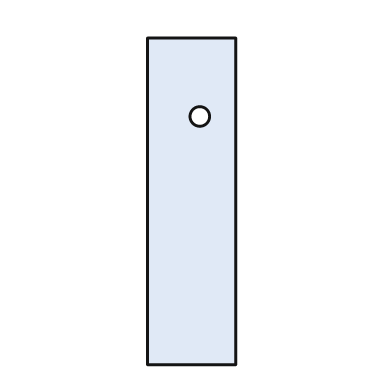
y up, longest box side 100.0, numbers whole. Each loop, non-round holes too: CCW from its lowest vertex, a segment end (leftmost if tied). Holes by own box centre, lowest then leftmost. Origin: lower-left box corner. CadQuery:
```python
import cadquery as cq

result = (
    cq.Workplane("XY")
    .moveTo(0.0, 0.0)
    .lineTo(27.0, 0.0)
    .lineTo(27.0, 100.0)
    .lineTo(0.0, 100.0)
    .close()
    .moveTo(16.0, 76.0)
    .circle(3.0)
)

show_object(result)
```